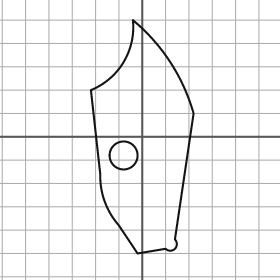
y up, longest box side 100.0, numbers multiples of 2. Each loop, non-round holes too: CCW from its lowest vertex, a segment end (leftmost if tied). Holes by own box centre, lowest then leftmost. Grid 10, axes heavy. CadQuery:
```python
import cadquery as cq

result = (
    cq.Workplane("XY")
    .moveTo(-2.0, -50.0)
    .lineTo(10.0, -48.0)
    .threePointArc((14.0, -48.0), (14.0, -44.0))
    .lineTo(22.0, 10.0)
    .threePointArc((12.0, 32.0), (-4.0, 50.0))
    .threePointArc((-8.0, 32.0), (-22.0, 20.0))
    .lineTo(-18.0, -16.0)
    .threePointArc((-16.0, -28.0), (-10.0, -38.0))
    .close()
    .moveTo(-8.0, -8.0)
    .circle(6.0)
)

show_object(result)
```